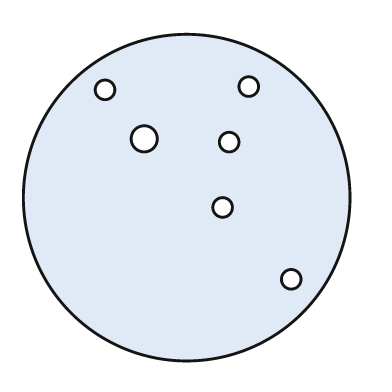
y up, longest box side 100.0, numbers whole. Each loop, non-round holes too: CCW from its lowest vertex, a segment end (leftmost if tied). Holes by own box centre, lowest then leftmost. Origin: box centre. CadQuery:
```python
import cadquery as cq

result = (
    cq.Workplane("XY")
    .moveTo(0.0, 0.0)
    .circle(50.0)
    .moveTo(32.0, -25.0)
    .circle(3.0)
    .moveTo(11.0, -3.0)
    .circle(3.0)
    .moveTo(13.0, 17.0)
    .circle(3.0)
    .moveTo(-13.0, 18.0)
    .circle(4.0)
    .moveTo(-25.0, 33.0)
    .circle(3.0)
    .moveTo(19.0, 34.0)
    .circle(3.0)
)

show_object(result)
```